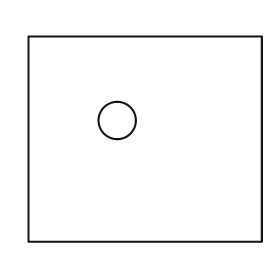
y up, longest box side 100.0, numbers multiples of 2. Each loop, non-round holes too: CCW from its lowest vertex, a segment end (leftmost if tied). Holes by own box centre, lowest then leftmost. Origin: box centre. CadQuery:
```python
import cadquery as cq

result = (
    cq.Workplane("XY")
    .moveTo(-50.0, -44.0)
    .lineTo(50.0, -44.0)
    .lineTo(50.0, 44.0)
    .lineTo(-50.0, 44.0)
    .close()
    .moveTo(-12.0, 8.0)
    .circle(8.0)
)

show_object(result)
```